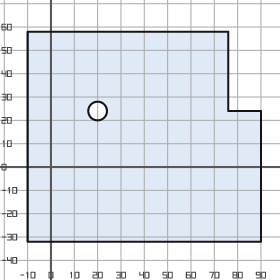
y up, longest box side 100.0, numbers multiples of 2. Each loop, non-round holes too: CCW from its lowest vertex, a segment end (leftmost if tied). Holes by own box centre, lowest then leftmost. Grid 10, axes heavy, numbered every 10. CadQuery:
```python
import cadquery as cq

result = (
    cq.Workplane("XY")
    .moveTo(-10.0, -32.0)
    .lineTo(90.0, -32.0)
    .lineTo(90.0, 24.0)
    .lineTo(76.0, 24.0)
    .lineTo(76.0, 58.0)
    .lineTo(-10.0, 58.0)
    .close()
    .moveTo(20.0, 24.0)
    .circle(4.0)
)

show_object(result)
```